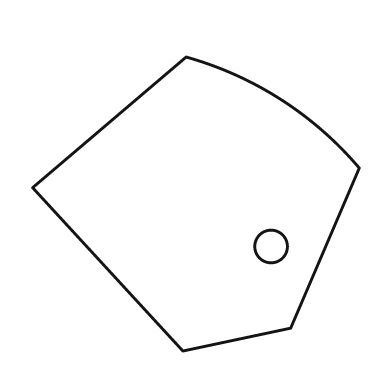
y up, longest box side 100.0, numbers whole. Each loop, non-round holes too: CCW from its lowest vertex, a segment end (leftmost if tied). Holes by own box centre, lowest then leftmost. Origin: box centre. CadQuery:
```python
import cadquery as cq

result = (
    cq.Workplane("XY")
    .moveTo(-4.0, -45.0)
    .lineTo(29.0, -38.0)
    .lineTo(50.0, 11.0)
    .threePointArc((26.0, 32.0), (-3.0, 45.0))
    .lineTo(-50.0, 5.0)
    .close()
    .moveTo(23.0, -13.0)
    .circle(5.0)
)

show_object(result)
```